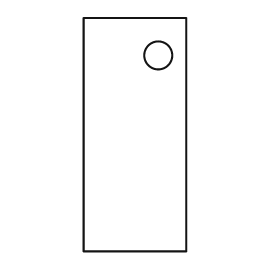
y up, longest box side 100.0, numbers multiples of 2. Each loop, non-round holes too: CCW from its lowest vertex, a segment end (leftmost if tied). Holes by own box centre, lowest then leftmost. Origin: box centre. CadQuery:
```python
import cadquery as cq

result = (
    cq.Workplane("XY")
    .moveTo(-22.0, -50.0)
    .lineTo(22.0, -50.0)
    .lineTo(22.0, 50.0)
    .lineTo(-22.0, 50.0)
    .close()
    .moveTo(10.0, 34.0)
    .circle(6.0)
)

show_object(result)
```